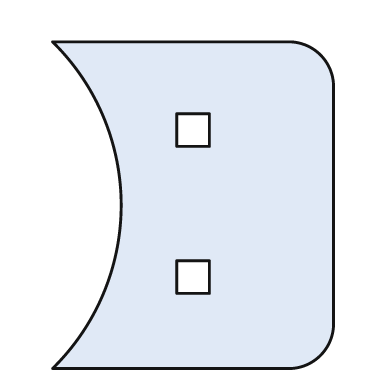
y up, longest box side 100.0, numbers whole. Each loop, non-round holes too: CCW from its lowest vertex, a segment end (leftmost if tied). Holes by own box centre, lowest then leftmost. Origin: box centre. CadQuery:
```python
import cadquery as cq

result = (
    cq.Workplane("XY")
    .moveTo(-43.0, -50.0)
    .lineTo(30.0, -50.0)
    .threePointArc((39.0, -46.0), (43.0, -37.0))
    .lineTo(43.0, 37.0)
    .threePointArc((39.0, 46.0), (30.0, 50.0))
    .lineTo(-43.0, 50.0)
    .threePointArc((-22.0, 0.0), (-43.0, -50.0))
    .close()
    .moveTo(-5.0, -27.0)
    .lineTo(5.0, -27.0)
    .lineTo(5.0, -17.0)
    .lineTo(-5.0, -17.0)
    .close()
    .moveTo(-5.0, 18.0)
    .lineTo(5.0, 18.0)
    .lineTo(5.0, 28.0)
    .lineTo(-5.0, 28.0)
    .close()
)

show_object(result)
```